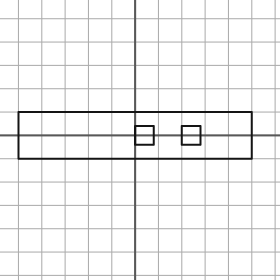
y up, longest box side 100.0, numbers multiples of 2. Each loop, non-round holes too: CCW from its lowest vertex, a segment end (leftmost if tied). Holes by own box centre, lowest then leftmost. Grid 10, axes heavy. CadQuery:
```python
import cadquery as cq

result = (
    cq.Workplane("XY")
    .moveTo(-50.0, -10.0)
    .lineTo(50.0, -10.0)
    .lineTo(50.0, 10.0)
    .lineTo(-50.0, 10.0)
    .close()
    .moveTo(0.0, -4.0)
    .lineTo(8.0, -4.0)
    .lineTo(8.0, 4.0)
    .lineTo(0.0, 4.0)
    .close()
    .moveTo(20.0, -4.0)
    .lineTo(28.0, -4.0)
    .lineTo(28.0, 4.0)
    .lineTo(20.0, 4.0)
    .close()
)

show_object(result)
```